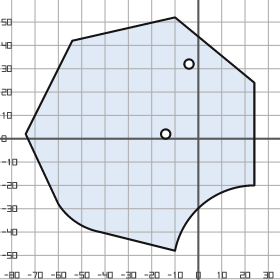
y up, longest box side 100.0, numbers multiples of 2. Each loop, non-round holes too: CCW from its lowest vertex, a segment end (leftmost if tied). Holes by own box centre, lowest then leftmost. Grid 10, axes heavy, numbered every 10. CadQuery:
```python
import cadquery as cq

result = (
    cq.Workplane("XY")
    .moveTo(-10.0, -48.0)
    .threePointArc((2.0, -28.0), (24.0, -20.0))
    .lineTo(24.0, 24.0)
    .lineTo(-10.0, 52.0)
    .lineTo(-54.0, 42.0)
    .lineTo(-74.0, 2.0)
    .lineTo(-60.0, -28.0)
    .threePointArc((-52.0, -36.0), (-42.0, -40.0))
    .close()
    .moveTo(-14.0, 2.0)
    .circle(2.0)
    .moveTo(-4.0, 32.0)
    .circle(2.0)
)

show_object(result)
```